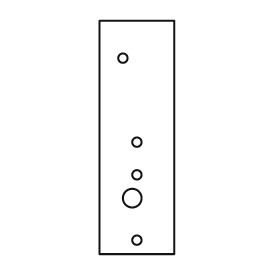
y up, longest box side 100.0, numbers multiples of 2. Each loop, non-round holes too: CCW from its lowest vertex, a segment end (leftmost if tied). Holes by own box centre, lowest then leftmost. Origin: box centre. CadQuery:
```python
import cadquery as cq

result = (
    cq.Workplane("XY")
    .moveTo(-16.0, -50.0)
    .lineTo(16.0, -50.0)
    .lineTo(16.0, 50.0)
    .lineTo(-16.0, 50.0)
    .close()
    .moveTo(0.0, -44.0)
    .circle(2.0)
    .moveTo(-2.0, -26.0)
    .circle(4.0)
    .moveTo(0.0, -16.0)
    .circle(2.0)
    .moveTo(0.0, -2.0)
    .circle(2.0)
    .moveTo(-6.0, 34.0)
    .circle(2.0)
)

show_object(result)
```